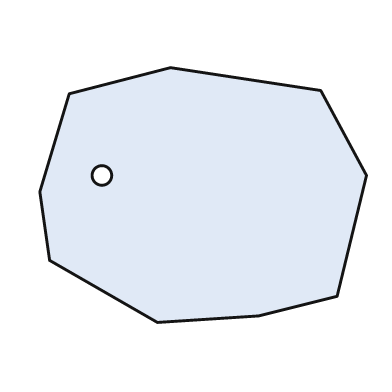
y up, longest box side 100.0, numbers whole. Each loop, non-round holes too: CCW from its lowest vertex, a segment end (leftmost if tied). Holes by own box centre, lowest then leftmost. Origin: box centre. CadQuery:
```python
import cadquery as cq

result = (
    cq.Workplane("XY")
    .moveTo(-14.0, -39.0)
    .lineTo(17.0, -37.0)
    .lineTo(41.0, -31.0)
    .lineTo(50.0, 6.0)
    .lineTo(36.0, 32.0)
    .lineTo(-10.0, 39.0)
    .lineTo(-41.0, 31.0)
    .lineTo(-50.0, 1.0)
    .lineTo(-47.0, -20.0)
    .close()
    .moveTo(-31.0, 6.0)
    .circle(3.0)
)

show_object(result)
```